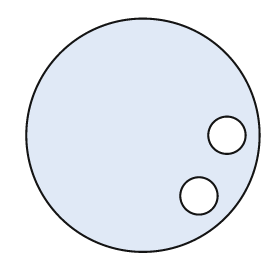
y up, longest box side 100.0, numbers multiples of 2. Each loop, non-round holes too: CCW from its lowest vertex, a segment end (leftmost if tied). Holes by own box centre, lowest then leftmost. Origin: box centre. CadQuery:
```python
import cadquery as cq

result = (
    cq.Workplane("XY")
    .moveTo(0.0, 0.0)
    .circle(50.0)
    .moveTo(24.0, -26.0)
    .circle(8.0)
    .moveTo(36.0, 0.0)
    .circle(8.0)
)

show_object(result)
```